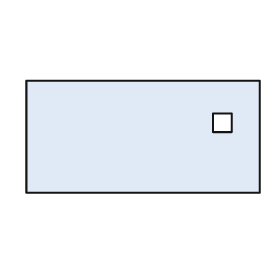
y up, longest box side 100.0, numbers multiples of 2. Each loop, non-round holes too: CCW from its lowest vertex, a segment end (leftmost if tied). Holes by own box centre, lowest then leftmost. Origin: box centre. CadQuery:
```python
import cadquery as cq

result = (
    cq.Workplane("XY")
    .moveTo(-50.0, -24.0)
    .lineTo(50.0, -24.0)
    .lineTo(50.0, 24.0)
    .lineTo(-50.0, 24.0)
    .close()
    .moveTo(30.0, 2.0)
    .lineTo(38.0, 2.0)
    .lineTo(38.0, 10.0)
    .lineTo(30.0, 10.0)
    .close()
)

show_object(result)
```